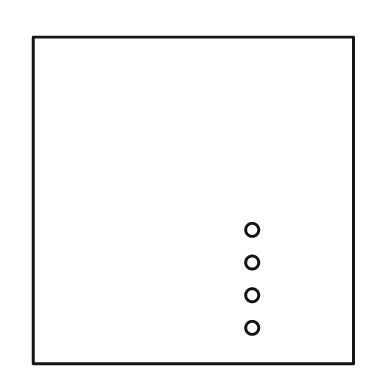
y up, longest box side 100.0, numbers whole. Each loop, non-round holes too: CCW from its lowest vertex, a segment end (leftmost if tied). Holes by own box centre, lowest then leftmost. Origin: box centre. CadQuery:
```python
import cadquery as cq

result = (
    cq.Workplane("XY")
    .moveTo(-49.0, -50.0)
    .lineTo(49.0, -50.0)
    .lineTo(49.0, 50.0)
    .lineTo(-49.0, 50.0)
    .close()
    .moveTo(18.0, -39.0)
    .circle(2.0)
    .moveTo(18.0, -29.0)
    .circle(2.0)
    .moveTo(18.0, -19.0)
    .circle(2.0)
    .moveTo(18.0, -9.0)
    .circle(2.0)
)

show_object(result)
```